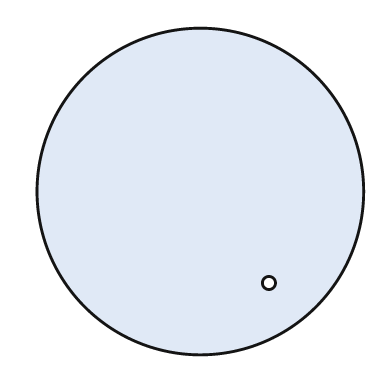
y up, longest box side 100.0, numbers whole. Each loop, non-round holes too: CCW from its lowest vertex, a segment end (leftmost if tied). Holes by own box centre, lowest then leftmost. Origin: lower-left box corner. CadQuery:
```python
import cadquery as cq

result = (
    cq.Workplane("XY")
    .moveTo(50.0, 50.0)
    .circle(50.0)
    .moveTo(71.0, 22.0)
    .circle(2.0)
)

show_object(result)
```